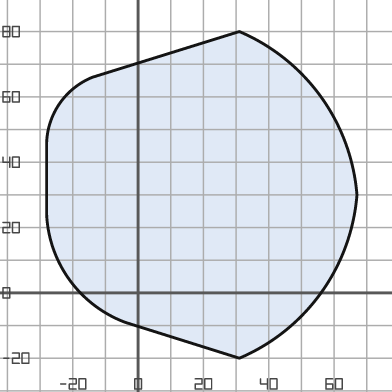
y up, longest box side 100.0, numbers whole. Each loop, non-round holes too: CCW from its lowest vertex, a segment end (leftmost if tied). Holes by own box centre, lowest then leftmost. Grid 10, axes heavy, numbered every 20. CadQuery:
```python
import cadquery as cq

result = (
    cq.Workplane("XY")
    .moveTo(31.0, -20.0)
    .threePointArc((56.0, 0.0), (67.0, 30.0))
    .threePointArc((56.0, 60.0), (31.0, 80.0))
    .lineTo(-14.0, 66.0)
    .threePointArc((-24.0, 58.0), (-28.0, 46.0))
    .lineTo(-28.0, 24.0)
    .threePointArc((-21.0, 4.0), (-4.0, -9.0))
    .close()
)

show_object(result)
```